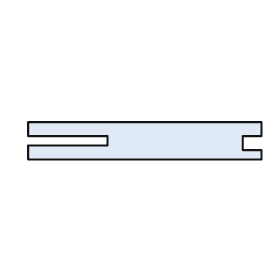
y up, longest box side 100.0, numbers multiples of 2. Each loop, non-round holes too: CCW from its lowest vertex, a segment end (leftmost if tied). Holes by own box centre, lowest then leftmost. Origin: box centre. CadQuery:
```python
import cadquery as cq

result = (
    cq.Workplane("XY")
    .moveTo(-50.0, -8.0)
    .lineTo(50.0, -8.0)
    .lineTo(50.0, -4.0)
    .lineTo(42.0, -4.0)
    .lineTo(42.0, 2.0)
    .lineTo(50.0, 2.0)
    .lineTo(50.0, 8.0)
    .lineTo(-50.0, 8.0)
    .lineTo(-50.0, 2.0)
    .lineTo(-16.0, 2.0)
    .lineTo(-16.0, -2.0)
    .lineTo(-50.0, -2.0)
    .close()
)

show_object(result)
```